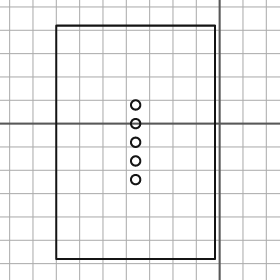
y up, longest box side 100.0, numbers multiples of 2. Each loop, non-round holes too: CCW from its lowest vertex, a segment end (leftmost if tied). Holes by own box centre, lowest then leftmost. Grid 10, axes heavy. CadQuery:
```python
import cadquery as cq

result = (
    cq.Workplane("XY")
    .moveTo(-70.0, -58.0)
    .lineTo(-2.0, -58.0)
    .lineTo(-2.0, 42.0)
    .lineTo(-70.0, 42.0)
    .close()
    .moveTo(-36.0, -24.0)
    .circle(2.0)
    .moveTo(-36.0, -16.0)
    .circle(2.0)
    .moveTo(-36.0, -8.0)
    .circle(2.0)
    .moveTo(-36.0, 0.0)
    .circle(2.0)
    .moveTo(-36.0, 8.0)
    .circle(2.0)
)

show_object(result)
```